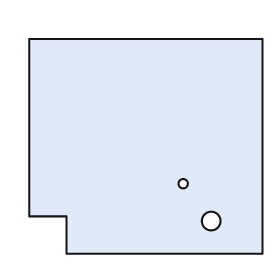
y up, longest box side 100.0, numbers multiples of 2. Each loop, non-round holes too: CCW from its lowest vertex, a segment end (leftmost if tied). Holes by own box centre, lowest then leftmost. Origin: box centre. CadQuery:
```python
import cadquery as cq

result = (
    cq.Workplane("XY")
    .moveTo(-34.0, -46.0)
    .lineTo(50.0, -46.0)
    .lineTo(50.0, 46.0)
    .lineTo(-50.0, 46.0)
    .lineTo(-50.0, -30.0)
    .lineTo(-34.0, -30.0)
    .close()
    .moveTo(28.0, -32.0)
    .circle(4.0)
    .moveTo(16.0, -16.0)
    .circle(2.0)
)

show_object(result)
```